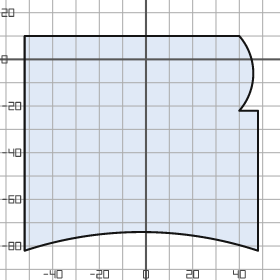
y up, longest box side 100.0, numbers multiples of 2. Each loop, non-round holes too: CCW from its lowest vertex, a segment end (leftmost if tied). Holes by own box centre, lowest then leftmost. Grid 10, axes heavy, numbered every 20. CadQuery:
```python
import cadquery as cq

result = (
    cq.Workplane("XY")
    .moveTo(-52.0, -82.0)
    .threePointArc((-2.0, -74.0), (48.0, -82.0))
    .lineTo(48.0, -22.0)
    .lineTo(40.0, -22.0)
    .threePointArc((46.0, -6.0), (40.0, 10.0))
    .lineTo(-52.0, 10.0)
    .close()
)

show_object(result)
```